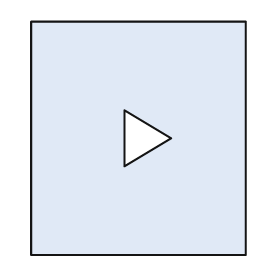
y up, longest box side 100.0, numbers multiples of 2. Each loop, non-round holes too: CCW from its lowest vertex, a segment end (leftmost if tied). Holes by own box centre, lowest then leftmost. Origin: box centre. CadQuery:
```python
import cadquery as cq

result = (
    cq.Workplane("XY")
    .moveTo(-46.0, -50.0)
    .lineTo(46.0, -50.0)
    .lineTo(46.0, 50.0)
    .lineTo(-46.0, 50.0)
    .close()
    .moveTo(-6.0, -12.0)
    .lineTo(14.0, 0.0)
    .lineTo(-6.0, 12.0)
    .close()
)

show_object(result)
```